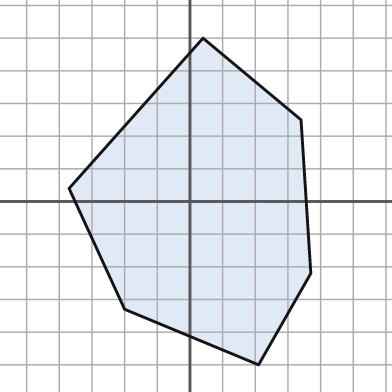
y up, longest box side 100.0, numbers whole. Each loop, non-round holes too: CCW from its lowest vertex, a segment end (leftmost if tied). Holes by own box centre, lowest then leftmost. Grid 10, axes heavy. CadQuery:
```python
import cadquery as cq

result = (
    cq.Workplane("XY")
    .moveTo(21.0, -50.0)
    .lineTo(37.0, -22.0)
    .lineTo(34.0, 25.0)
    .lineTo(4.0, 50.0)
    .lineTo(-37.0, 4.0)
    .lineTo(-20.0, -33.0)
    .close()
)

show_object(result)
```